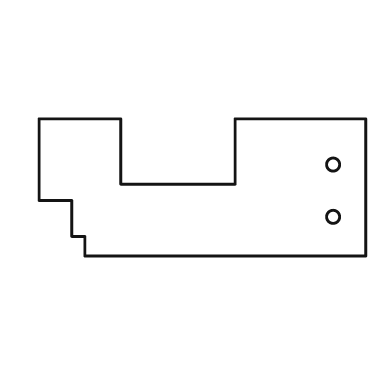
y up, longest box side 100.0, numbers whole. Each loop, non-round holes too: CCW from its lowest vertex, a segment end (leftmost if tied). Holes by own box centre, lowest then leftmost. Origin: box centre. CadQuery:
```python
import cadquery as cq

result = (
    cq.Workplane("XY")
    .moveTo(-36.0, -21.0)
    .lineTo(50.0, -21.0)
    .lineTo(50.0, 21.0)
    .lineTo(10.0, 21.0)
    .lineTo(10.0, 1.0)
    .lineTo(-25.0, 1.0)
    .lineTo(-25.0, 21.0)
    .lineTo(-50.0, 21.0)
    .lineTo(-50.0, -4.0)
    .lineTo(-40.0, -4.0)
    .lineTo(-40.0, -15.0)
    .lineTo(-36.0, -15.0)
    .close()
    .moveTo(40.0, -9.0)
    .circle(2.0)
    .moveTo(40.0, 7.0)
    .circle(2.0)
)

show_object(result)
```